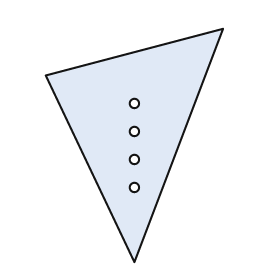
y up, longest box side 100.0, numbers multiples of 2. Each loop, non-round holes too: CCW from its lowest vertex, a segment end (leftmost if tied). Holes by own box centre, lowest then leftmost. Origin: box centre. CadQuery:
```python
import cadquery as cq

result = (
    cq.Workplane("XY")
    .moveTo(0.0, -50.0)
    .lineTo(38.0, 50.0)
    .lineTo(-38.0, 30.0)
    .close()
    .moveTo(0.0, -18.0)
    .circle(2.0)
    .moveTo(0.0, -6.0)
    .circle(2.0)
    .moveTo(0.0, 6.0)
    .circle(2.0)
    .moveTo(0.0, 18.0)
    .circle(2.0)
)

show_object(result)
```